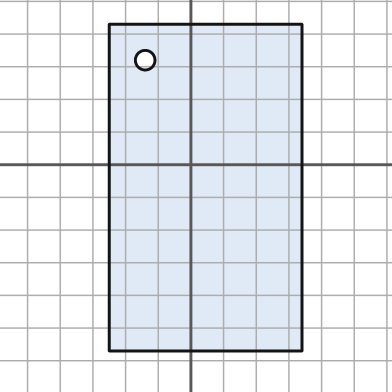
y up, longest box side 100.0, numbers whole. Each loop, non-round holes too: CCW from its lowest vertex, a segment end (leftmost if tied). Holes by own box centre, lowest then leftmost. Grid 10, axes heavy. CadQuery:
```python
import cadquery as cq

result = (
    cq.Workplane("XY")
    .moveTo(-25.0, -57.0)
    .lineTo(34.0, -57.0)
    .lineTo(34.0, 43.0)
    .lineTo(-25.0, 43.0)
    .close()
    .moveTo(-14.0, 32.0)
    .circle(3.0)
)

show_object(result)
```